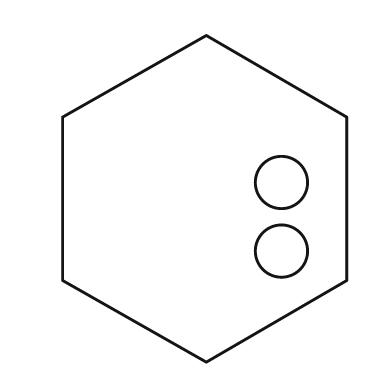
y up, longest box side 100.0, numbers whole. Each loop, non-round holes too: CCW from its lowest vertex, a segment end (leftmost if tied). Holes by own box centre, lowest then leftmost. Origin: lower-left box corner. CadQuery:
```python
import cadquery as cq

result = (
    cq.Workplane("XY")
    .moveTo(44.0, 0.0)
    .lineTo(87.0, 25.0)
    .lineTo(87.0, 75.0)
    .lineTo(44.0, 100.0)
    .lineTo(0.0, 75.0)
    .lineTo(0.0, 25.0)
    .close()
    .moveTo(67.0, 34.0)
    .circle(8.0)
    .moveTo(67.0, 55.0)
    .circle(8.0)
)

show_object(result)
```